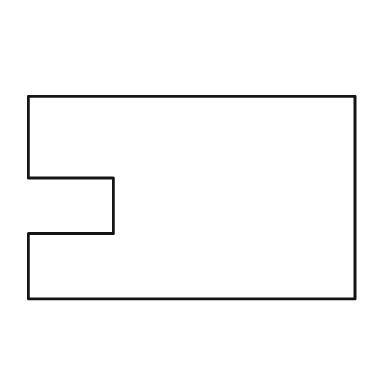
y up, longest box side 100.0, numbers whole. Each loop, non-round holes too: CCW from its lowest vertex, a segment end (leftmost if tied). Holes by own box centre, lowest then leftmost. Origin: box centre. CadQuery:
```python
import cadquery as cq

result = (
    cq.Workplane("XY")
    .moveTo(-50.0, -31.0)
    .lineTo(50.0, -31.0)
    .lineTo(50.0, 31.0)
    .lineTo(-50.0, 31.0)
    .lineTo(-50.0, 6.0)
    .lineTo(-24.0, 6.0)
    .lineTo(-24.0, -11.0)
    .lineTo(-50.0, -11.0)
    .close()
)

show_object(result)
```